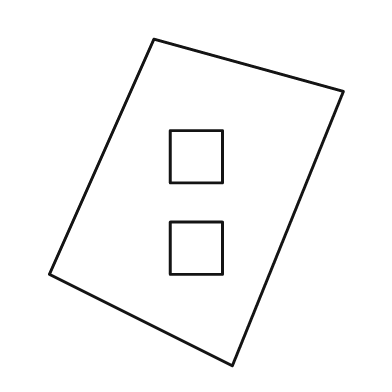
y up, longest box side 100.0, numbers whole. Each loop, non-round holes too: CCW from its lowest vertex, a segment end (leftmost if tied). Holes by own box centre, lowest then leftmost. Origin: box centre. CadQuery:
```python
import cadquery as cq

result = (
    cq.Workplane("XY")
    .moveTo(11.0, -50.0)
    .lineTo(45.0, 34.0)
    .lineTo(-13.0, 50.0)
    .lineTo(-45.0, -22.0)
    .close()
    .moveTo(-8.0, -22.0)
    .lineTo(8.0, -22.0)
    .lineTo(8.0, -6.0)
    .lineTo(-8.0, -6.0)
    .close()
    .moveTo(-8.0, 6.0)
    .lineTo(8.0, 6.0)
    .lineTo(8.0, 22.0)
    .lineTo(-8.0, 22.0)
    .close()
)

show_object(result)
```